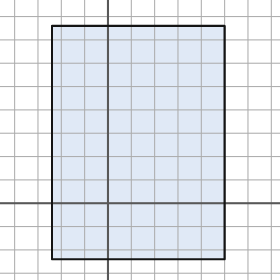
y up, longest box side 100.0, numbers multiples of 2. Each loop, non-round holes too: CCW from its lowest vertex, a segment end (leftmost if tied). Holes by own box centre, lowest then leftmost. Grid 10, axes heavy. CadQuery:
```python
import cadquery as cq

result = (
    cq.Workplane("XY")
    .moveTo(-24.0, -24.0)
    .lineTo(50.0, -24.0)
    .lineTo(50.0, 76.0)
    .lineTo(-24.0, 76.0)
    .close()
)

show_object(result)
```